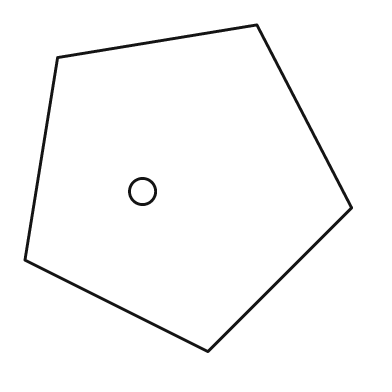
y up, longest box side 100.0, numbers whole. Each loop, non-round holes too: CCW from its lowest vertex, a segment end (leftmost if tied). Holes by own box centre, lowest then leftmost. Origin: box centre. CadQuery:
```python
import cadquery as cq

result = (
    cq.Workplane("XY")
    .moveTo(6.0, -50.0)
    .lineTo(50.0, -6.0)
    .lineTo(21.0, 50.0)
    .lineTo(-40.0, 40.0)
    .lineTo(-50.0, -22.0)
    .close()
    .moveTo(-14.0, -1.0)
    .circle(4.0)
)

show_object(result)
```